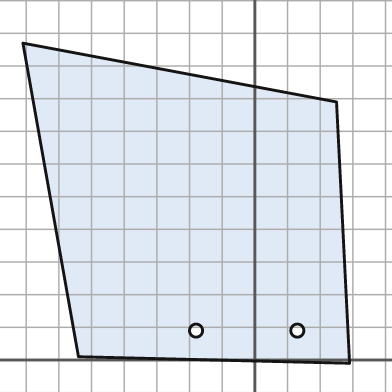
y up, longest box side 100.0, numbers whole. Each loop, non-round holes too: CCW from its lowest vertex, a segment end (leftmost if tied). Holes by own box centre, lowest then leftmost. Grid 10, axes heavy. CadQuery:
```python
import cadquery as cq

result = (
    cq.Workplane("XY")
    .moveTo(29.0, -1.0)
    .lineTo(25.0, 79.0)
    .lineTo(-71.0, 97.0)
    .lineTo(-54.0, 1.0)
    .close()
    .moveTo(-18.0, 9.0)
    .circle(2.0)
    .moveTo(13.0, 9.0)
    .circle(2.0)
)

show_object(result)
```